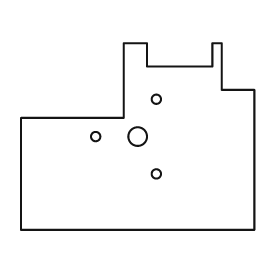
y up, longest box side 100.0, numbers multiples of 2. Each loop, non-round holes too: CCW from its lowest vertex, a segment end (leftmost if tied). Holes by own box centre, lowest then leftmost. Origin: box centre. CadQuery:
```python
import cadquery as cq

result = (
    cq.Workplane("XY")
    .moveTo(-50.0, -40.0)
    .lineTo(50.0, -40.0)
    .lineTo(50.0, 20.0)
    .lineTo(36.0, 20.0)
    .lineTo(36.0, 40.0)
    .lineTo(32.0, 40.0)
    .lineTo(32.0, 30.0)
    .lineTo(4.0, 30.0)
    .lineTo(4.0, 40.0)
    .lineTo(-6.0, 40.0)
    .lineTo(-6.0, 8.0)
    .lineTo(-50.0, 8.0)
    .close()
    .moveTo(8.0, -16.0)
    .circle(2.0)
    .moveTo(-18.0, 0.0)
    .circle(2.0)
    .moveTo(0.0, 0.0)
    .circle(4.0)
    .moveTo(8.0, 16.0)
    .circle(2.0)
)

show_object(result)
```